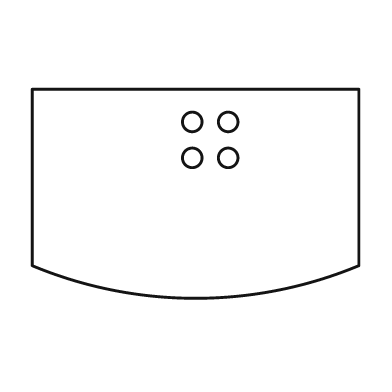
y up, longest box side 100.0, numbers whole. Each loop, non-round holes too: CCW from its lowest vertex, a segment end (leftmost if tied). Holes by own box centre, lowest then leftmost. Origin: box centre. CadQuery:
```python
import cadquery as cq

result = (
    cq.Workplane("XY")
    .moveTo(-50.0, -22.0)
    .threePointArc((0.0, -32.0), (50.0, -22.0))
    .lineTo(50.0, 32.0)
    .lineTo(-50.0, 32.0)
    .close()
    .moveTo(-1.0, 11.0)
    .circle(3.0)
    .moveTo(10.0, 11.0)
    .circle(3.0)
    .moveTo(-1.0, 22.0)
    .circle(3.0)
    .moveTo(10.0, 22.0)
    .circle(3.0)
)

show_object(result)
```